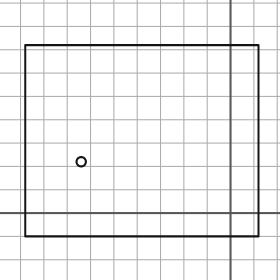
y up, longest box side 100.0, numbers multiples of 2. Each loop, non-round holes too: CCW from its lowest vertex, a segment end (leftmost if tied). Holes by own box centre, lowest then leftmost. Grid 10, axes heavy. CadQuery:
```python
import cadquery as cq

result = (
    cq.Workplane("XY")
    .moveTo(-88.0, -10.0)
    .lineTo(12.0, -10.0)
    .lineTo(12.0, 72.0)
    .lineTo(-88.0, 72.0)
    .close()
    .moveTo(-64.0, 22.0)
    .circle(2.0)
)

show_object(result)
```